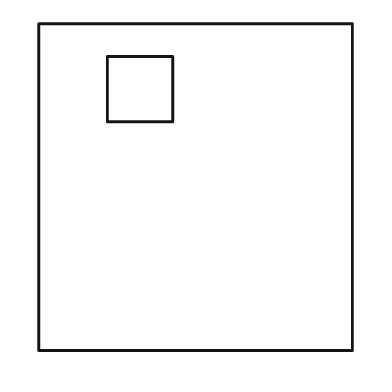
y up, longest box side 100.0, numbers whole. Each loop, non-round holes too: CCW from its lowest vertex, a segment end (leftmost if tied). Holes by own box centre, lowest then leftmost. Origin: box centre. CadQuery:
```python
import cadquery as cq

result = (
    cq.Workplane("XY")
    .moveTo(-48.0, -50.0)
    .lineTo(48.0, -50.0)
    .lineTo(48.0, 50.0)
    .lineTo(-48.0, 50.0)
    .close()
    .moveTo(-27.0, 20.0)
    .lineTo(-7.0, 20.0)
    .lineTo(-7.0, 40.0)
    .lineTo(-27.0, 40.0)
    .close()
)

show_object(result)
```